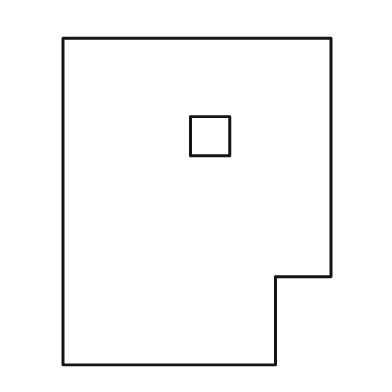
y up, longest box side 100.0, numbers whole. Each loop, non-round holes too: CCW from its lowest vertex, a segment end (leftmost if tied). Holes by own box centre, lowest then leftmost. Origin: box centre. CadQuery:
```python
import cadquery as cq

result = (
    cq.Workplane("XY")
    .moveTo(-41.0, -50.0)
    .lineTo(24.0, -50.0)
    .lineTo(24.0, -23.0)
    .lineTo(41.0, -23.0)
    .lineTo(41.0, 50.0)
    .lineTo(-41.0, 50.0)
    .close()
    .moveTo(-2.0, 14.0)
    .lineTo(10.0, 14.0)
    .lineTo(10.0, 26.0)
    .lineTo(-2.0, 26.0)
    .close()
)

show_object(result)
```